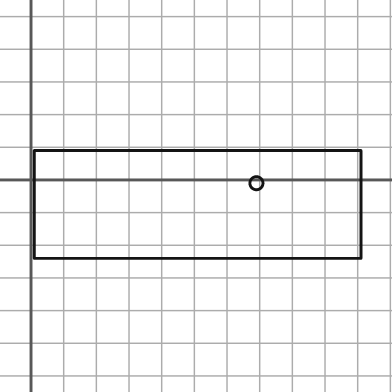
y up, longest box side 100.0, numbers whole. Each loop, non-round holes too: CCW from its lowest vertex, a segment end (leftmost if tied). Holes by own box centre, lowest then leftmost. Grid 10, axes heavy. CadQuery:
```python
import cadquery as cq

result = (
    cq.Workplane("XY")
    .moveTo(1.0, -24.0)
    .lineTo(101.0, -24.0)
    .lineTo(101.0, 9.0)
    .lineTo(1.0, 9.0)
    .close()
    .moveTo(69.0, -1.0)
    .circle(2.0)
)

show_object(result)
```